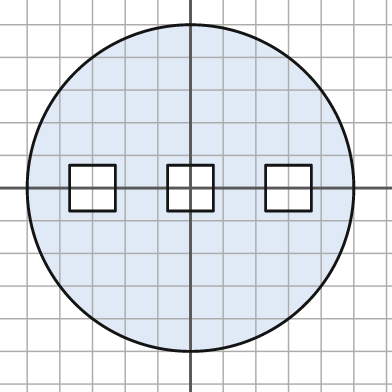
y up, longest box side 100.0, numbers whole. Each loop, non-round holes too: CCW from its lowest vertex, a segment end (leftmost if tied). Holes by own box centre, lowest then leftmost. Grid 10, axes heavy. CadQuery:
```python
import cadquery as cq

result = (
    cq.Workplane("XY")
    .moveTo(0.0, 0.0)
    .circle(50.0)
    .moveTo(-37.0, -7.0)
    .lineTo(-23.0, -7.0)
    .lineTo(-23.0, 7.0)
    .lineTo(-37.0, 7.0)
    .close()
    .moveTo(-7.0, -7.0)
    .lineTo(7.0, -7.0)
    .lineTo(7.0, 7.0)
    .lineTo(-7.0, 7.0)
    .close()
    .moveTo(23.0, -7.0)
    .lineTo(37.0, -7.0)
    .lineTo(37.0, 7.0)
    .lineTo(23.0, 7.0)
    .close()
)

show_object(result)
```